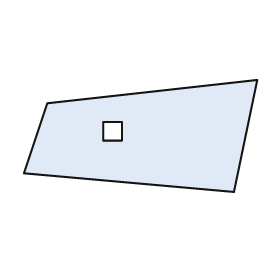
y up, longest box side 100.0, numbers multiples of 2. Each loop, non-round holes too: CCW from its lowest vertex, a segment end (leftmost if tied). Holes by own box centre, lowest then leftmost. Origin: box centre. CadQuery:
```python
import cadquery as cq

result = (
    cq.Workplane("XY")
    .moveTo(40.0, -24.0)
    .lineTo(50.0, 24.0)
    .lineTo(-40.0, 14.0)
    .lineTo(-50.0, -16.0)
    .close()
    .moveTo(-16.0, -2.0)
    .lineTo(-8.0, -2.0)
    .lineTo(-8.0, 6.0)
    .lineTo(-16.0, 6.0)
    .close()
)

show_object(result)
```